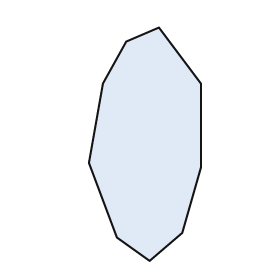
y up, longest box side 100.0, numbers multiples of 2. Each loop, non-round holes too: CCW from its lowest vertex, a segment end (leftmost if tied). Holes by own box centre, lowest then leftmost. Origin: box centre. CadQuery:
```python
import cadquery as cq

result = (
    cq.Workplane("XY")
    .moveTo(2.0, -50.0)
    .lineTo(16.0, -38.0)
    .lineTo(24.0, -10.0)
    .lineTo(24.0, 26.0)
    .lineTo(6.0, 50.0)
    .lineTo(-8.0, 44.0)
    .lineTo(-18.0, 26.0)
    .lineTo(-24.0, -8.0)
    .lineTo(-12.0, -40.0)
    .close()
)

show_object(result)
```